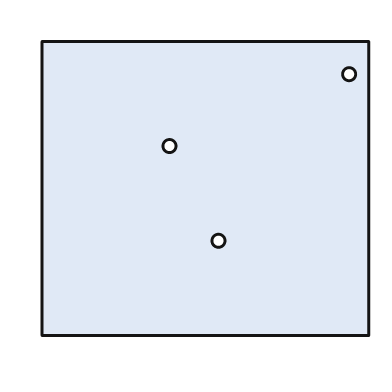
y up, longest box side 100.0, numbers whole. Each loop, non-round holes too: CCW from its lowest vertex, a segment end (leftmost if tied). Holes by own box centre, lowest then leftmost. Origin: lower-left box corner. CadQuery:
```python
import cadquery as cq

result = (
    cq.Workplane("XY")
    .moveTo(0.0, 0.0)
    .lineTo(100.0, 0.0)
    .lineTo(100.0, 90.0)
    .lineTo(0.0, 90.0)
    .close()
    .moveTo(54.0, 29.0)
    .circle(2.0)
    .moveTo(39.0, 58.0)
    .circle(2.0)
    .moveTo(94.0, 80.0)
    .circle(2.0)
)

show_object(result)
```